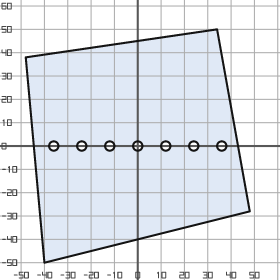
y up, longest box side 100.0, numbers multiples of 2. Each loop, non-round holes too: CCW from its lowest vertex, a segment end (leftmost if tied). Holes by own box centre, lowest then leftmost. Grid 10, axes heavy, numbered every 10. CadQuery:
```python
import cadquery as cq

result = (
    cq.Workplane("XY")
    .moveTo(-40.0, -50.0)
    .lineTo(48.0, -28.0)
    .lineTo(34.0, 50.0)
    .lineTo(-48.0, 38.0)
    .close()
    .moveTo(-36.0, 0.0)
    .circle(2.0)
    .moveTo(-24.0, 0.0)
    .circle(2.0)
    .moveTo(-12.0, 0.0)
    .circle(2.0)
    .moveTo(0.0, 0.0)
    .circle(2.0)
    .moveTo(12.0, 0.0)
    .circle(2.0)
    .moveTo(24.0, 0.0)
    .circle(2.0)
    .moveTo(36.0, 0.0)
    .circle(2.0)
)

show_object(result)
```